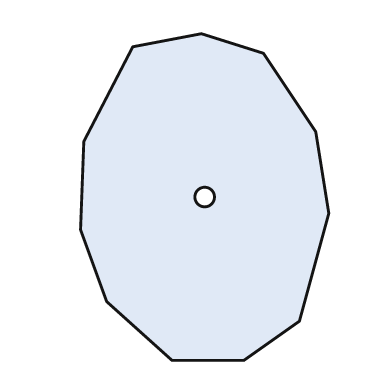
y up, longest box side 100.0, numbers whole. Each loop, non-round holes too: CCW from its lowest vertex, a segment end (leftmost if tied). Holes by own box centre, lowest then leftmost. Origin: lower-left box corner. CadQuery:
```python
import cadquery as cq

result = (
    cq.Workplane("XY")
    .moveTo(28.0, 0.0)
    .lineTo(50.0, 0.0)
    .lineTo(67.0, 12.0)
    .lineTo(76.0, 45.0)
    .lineTo(72.0, 70.0)
    .lineTo(56.0, 94.0)
    .lineTo(37.0, 100.0)
    .lineTo(16.0, 96.0)
    .lineTo(1.0, 67.0)
    .lineTo(0.0, 40.0)
    .lineTo(8.0, 18.0)
    .close()
    .moveTo(38.0, 50.0)
    .circle(3.0)
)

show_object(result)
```